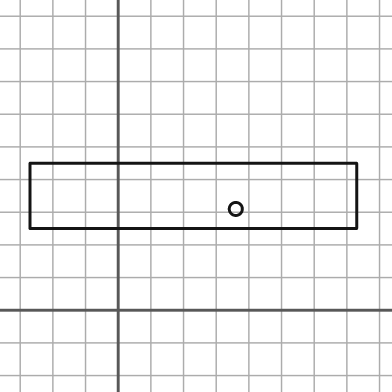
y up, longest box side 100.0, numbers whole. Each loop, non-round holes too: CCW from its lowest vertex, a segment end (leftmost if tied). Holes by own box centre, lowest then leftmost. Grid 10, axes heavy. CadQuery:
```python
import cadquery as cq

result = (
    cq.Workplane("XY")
    .moveTo(-27.0, 25.0)
    .lineTo(73.0, 25.0)
    .lineTo(73.0, 45.0)
    .lineTo(-27.0, 45.0)
    .close()
    .moveTo(36.0, 31.0)
    .circle(2.0)
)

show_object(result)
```